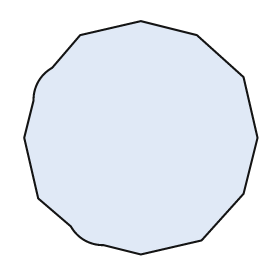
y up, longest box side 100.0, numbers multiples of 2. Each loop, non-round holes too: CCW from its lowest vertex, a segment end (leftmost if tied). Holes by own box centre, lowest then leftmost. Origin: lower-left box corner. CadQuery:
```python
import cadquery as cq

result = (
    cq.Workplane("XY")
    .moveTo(50.0, 0.0)
    .lineTo(76.0, 6.0)
    .lineTo(94.0, 26.0)
    .lineTo(100.0, 50.0)
    .lineTo(94.0, 76.0)
    .lineTo(74.0, 94.0)
    .lineTo(50.0, 100.0)
    .lineTo(24.0, 94.0)
    .lineTo(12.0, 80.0)
    .threePointArc((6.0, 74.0), (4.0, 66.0))
    .lineTo(0.0, 50.0)
    .lineTo(6.0, 24.0)
    .lineTo(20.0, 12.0)
    .threePointArc((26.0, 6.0), (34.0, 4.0))
    .close()
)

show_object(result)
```